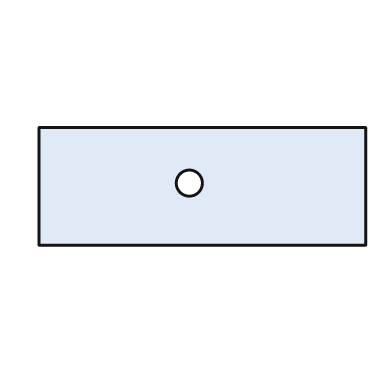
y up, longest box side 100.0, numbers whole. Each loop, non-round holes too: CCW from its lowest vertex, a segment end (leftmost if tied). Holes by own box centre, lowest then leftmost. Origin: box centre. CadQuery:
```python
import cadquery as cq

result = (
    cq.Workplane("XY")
    .moveTo(-50.0, -18.0)
    .lineTo(50.0, -18.0)
    .lineTo(50.0, 18.0)
    .lineTo(-50.0, 18.0)
    .close()
    .moveTo(-4.0, 1.0)
    .circle(4.0)
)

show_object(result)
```